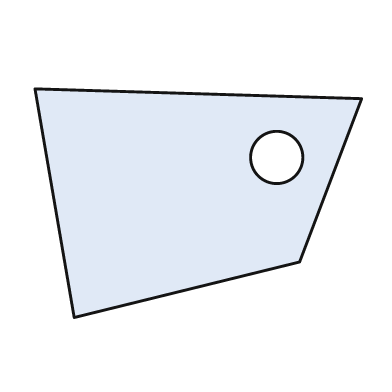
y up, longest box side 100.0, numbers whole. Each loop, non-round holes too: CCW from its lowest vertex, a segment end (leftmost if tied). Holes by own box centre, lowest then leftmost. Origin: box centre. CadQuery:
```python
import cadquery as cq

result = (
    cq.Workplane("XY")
    .moveTo(-38.0, -35.0)
    .lineTo(31.0, -18.0)
    .lineTo(50.0, 32.0)
    .lineTo(-50.0, 35.0)
    .close()
    .moveTo(24.0, 14.0)
    .circle(8.0)
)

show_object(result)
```